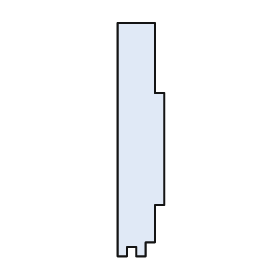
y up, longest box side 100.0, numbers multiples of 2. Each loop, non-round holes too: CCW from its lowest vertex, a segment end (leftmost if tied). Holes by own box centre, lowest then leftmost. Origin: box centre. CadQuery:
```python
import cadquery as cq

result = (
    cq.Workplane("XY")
    .moveTo(-10.0, -50.0)
    .lineTo(-6.0, -50.0)
    .lineTo(-6.0, -46.0)
    .lineTo(-2.0, -46.0)
    .lineTo(-2.0, -50.0)
    .lineTo(2.0, -50.0)
    .lineTo(2.0, -44.0)
    .lineTo(6.0, -44.0)
    .lineTo(6.0, -28.0)
    .lineTo(10.0, -28.0)
    .lineTo(10.0, 20.0)
    .lineTo(6.0, 20.0)
    .lineTo(6.0, 50.0)
    .lineTo(-10.0, 50.0)
    .close()
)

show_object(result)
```